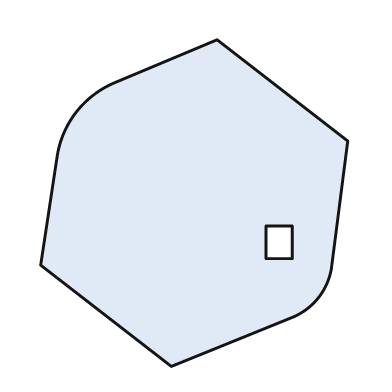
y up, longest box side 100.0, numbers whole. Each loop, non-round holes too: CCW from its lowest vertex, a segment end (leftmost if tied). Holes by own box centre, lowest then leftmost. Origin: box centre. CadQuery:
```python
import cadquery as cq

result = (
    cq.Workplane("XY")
    .moveTo(-7.0, -50.0)
    .lineTo(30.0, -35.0)
    .threePointArc((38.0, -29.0), (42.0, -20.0))
    .lineTo(47.0, 19.0)
    .lineTo(7.0, 50.0)
    .lineTo(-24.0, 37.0)
    .threePointArc((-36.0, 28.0), (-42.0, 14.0))
    .lineTo(-47.0, -19.0)
    .close()
    .moveTo(22.0, -17.0)
    .lineTo(30.0, -17.0)
    .lineTo(30.0, -7.0)
    .lineTo(22.0, -7.0)
    .close()
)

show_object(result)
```